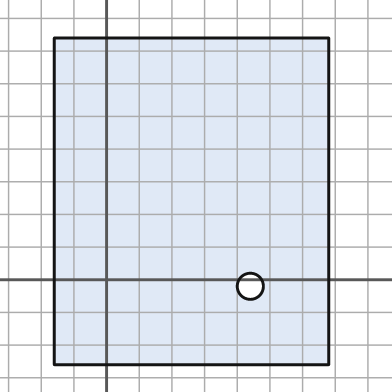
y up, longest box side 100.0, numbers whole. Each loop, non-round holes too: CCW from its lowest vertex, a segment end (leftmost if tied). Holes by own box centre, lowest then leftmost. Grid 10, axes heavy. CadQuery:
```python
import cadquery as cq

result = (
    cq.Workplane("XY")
    .moveTo(-16.0, -26.0)
    .lineTo(68.0, -26.0)
    .lineTo(68.0, 74.0)
    .lineTo(-16.0, 74.0)
    .close()
    .moveTo(44.0, -2.0)
    .circle(4.0)
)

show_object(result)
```